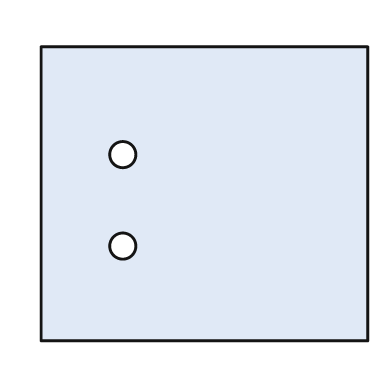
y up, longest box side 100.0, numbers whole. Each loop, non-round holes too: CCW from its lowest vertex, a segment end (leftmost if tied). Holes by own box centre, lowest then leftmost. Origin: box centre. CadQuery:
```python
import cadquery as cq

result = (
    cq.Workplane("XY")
    .moveTo(-50.0, -45.0)
    .lineTo(50.0, -45.0)
    .lineTo(50.0, 45.0)
    .lineTo(-50.0, 45.0)
    .close()
    .moveTo(-25.0, -16.0)
    .circle(4.0)
    .moveTo(-25.0, 12.0)
    .circle(4.0)
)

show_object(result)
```